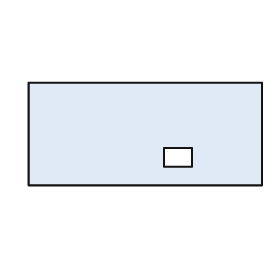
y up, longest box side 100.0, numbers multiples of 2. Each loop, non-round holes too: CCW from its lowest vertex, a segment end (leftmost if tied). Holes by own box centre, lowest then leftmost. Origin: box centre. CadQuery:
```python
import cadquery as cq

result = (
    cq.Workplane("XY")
    .moveTo(-50.0, -22.0)
    .lineTo(50.0, -22.0)
    .lineTo(50.0, 22.0)
    .lineTo(-50.0, 22.0)
    .close()
    .moveTo(8.0, -14.0)
    .lineTo(20.0, -14.0)
    .lineTo(20.0, -6.0)
    .lineTo(8.0, -6.0)
    .close()
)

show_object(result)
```